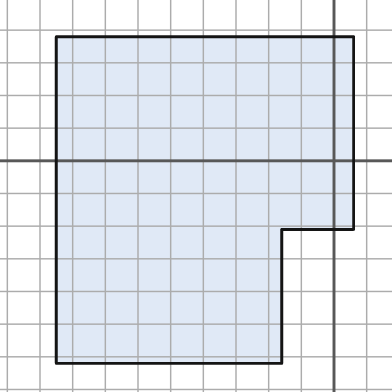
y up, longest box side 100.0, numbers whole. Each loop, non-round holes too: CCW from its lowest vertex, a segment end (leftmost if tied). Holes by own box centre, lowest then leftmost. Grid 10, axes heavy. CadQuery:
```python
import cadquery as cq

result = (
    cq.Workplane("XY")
    .moveTo(-85.0, -62.0)
    .lineTo(-16.0, -62.0)
    .lineTo(-16.0, -21.0)
    .lineTo(6.0, -21.0)
    .lineTo(6.0, 38.0)
    .lineTo(-85.0, 38.0)
    .close()
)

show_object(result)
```